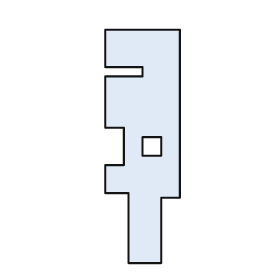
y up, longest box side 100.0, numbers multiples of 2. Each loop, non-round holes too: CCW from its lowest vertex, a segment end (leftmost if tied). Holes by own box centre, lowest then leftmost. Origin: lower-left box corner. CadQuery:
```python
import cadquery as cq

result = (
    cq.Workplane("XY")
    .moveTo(10.0, 0.0)
    .lineTo(24.0, 0.0)
    .lineTo(24.0, 28.0)
    .lineTo(32.0, 28.0)
    .lineTo(32.0, 100.0)
    .lineTo(0.0, 100.0)
    .lineTo(0.0, 84.0)
    .lineTo(16.0, 84.0)
    .lineTo(16.0, 80.0)
    .lineTo(0.0, 80.0)
    .lineTo(0.0, 58.0)
    .lineTo(8.0, 58.0)
    .lineTo(8.0, 42.0)
    .lineTo(0.0, 42.0)
    .lineTo(0.0, 30.0)
    .lineTo(10.0, 30.0)
    .close()
    .moveTo(16.0, 46.0)
    .lineTo(24.0, 46.0)
    .lineTo(24.0, 54.0)
    .lineTo(16.0, 54.0)
    .close()
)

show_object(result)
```